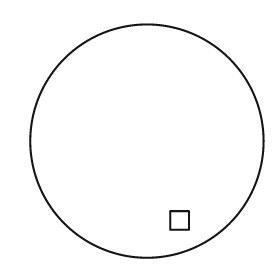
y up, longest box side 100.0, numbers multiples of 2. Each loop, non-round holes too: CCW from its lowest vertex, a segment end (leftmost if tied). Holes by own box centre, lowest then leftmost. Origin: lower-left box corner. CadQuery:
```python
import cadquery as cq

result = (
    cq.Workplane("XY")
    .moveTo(50.0, 50.0)
    .circle(50.0)
    .moveTo(60.0, 12.0)
    .lineTo(68.0, 12.0)
    .lineTo(68.0, 20.0)
    .lineTo(60.0, 20.0)
    .close()
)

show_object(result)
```